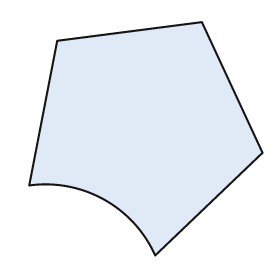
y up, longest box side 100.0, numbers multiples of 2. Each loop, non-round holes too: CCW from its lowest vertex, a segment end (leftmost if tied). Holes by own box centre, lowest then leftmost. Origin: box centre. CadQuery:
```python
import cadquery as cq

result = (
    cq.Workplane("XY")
    .moveTo(4.0, -50.0)
    .lineTo(50.0, -6.0)
    .lineTo(24.0, 50.0)
    .lineTo(-38.0, 42.0)
    .lineTo(-50.0, -20.0)
    .threePointArc((-18.0, -26.0), (4.0, -50.0))
    .close()
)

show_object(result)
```